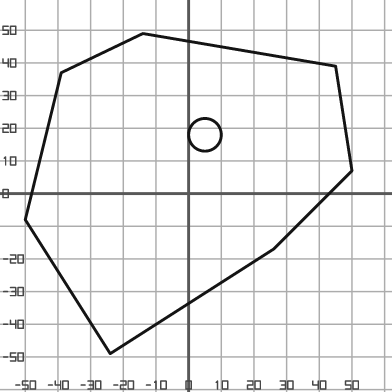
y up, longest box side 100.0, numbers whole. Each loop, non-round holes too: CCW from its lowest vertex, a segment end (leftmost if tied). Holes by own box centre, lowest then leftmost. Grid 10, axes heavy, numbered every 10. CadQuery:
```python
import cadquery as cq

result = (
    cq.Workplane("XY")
    .moveTo(-24.0, -49.0)
    .lineTo(26.0, -17.0)
    .lineTo(50.0, 7.0)
    .lineTo(45.0, 39.0)
    .lineTo(-14.0, 49.0)
    .lineTo(-39.0, 37.0)
    .lineTo(-50.0, -8.0)
    .close()
    .moveTo(5.0, 18.0)
    .circle(5.0)
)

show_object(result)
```